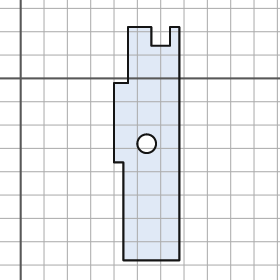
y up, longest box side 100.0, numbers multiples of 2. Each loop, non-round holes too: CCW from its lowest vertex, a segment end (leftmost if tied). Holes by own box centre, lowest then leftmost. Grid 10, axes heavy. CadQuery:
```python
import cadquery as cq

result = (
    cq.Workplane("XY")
    .moveTo(44.0, -78.0)
    .lineTo(68.0, -78.0)
    .lineTo(68.0, 22.0)
    .lineTo(64.0, 22.0)
    .lineTo(64.0, 14.0)
    .lineTo(56.0, 14.0)
    .lineTo(56.0, 22.0)
    .lineTo(46.0, 22.0)
    .lineTo(46.0, -2.0)
    .lineTo(40.0, -2.0)
    .lineTo(40.0, -36.0)
    .lineTo(44.0, -36.0)
    .close()
    .moveTo(54.0, -28.0)
    .circle(4.0)
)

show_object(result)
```